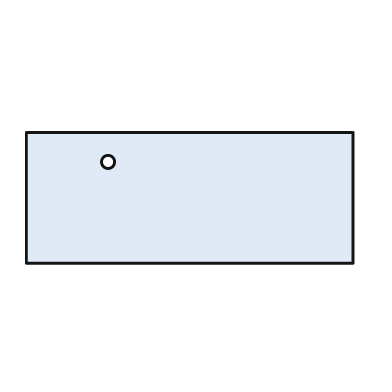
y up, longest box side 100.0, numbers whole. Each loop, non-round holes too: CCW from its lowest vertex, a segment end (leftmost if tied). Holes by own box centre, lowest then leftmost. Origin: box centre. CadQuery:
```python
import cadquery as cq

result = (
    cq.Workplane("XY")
    .moveTo(-50.0, -20.0)
    .lineTo(50.0, -20.0)
    .lineTo(50.0, 20.0)
    .lineTo(-50.0, 20.0)
    .close()
    .moveTo(-25.0, 11.0)
    .circle(2.0)
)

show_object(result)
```